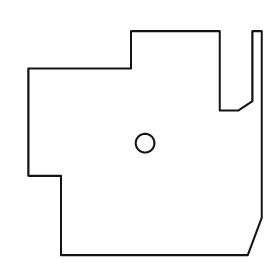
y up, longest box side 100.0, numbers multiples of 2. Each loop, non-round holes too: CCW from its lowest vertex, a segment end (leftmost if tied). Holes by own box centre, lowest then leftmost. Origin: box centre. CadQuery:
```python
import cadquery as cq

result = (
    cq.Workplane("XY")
    .moveTo(-36.0, -48.0)
    .lineTo(44.0, -48.0)
    .lineTo(50.0, -32.0)
    .lineTo(50.0, 48.0)
    .lineTo(46.0, 48.0)
    .lineTo(46.0, 18.0)
    .lineTo(40.0, 14.0)
    .lineTo(32.0, 14.0)
    .lineTo(32.0, 48.0)
    .lineTo(-6.0, 48.0)
    .lineTo(-6.0, 32.0)
    .lineTo(-50.0, 32.0)
    .lineTo(-50.0, -14.0)
    .lineTo(-36.0, -14.0)
    .close()
    .moveTo(0.0, 0.0)
    .circle(4.0)
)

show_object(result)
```